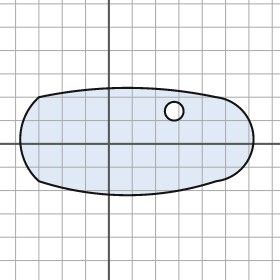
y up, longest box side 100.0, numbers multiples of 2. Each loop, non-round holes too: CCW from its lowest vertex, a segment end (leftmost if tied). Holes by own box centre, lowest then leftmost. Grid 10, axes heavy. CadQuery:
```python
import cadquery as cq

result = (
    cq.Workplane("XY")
    .moveTo(-30.0, -16.0)
    .threePointArc((8.0, -22.0), (46.0, -16.0))
    .threePointArc((62.0, 2.0), (46.0, 20.0))
    .threePointArc((8.0, 24.0), (-30.0, 20.0))
    .threePointArc((-38.0, 2.0), (-30.0, -16.0))
    .close()
    .moveTo(28.0, 14.0)
    .circle(4.0)
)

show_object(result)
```